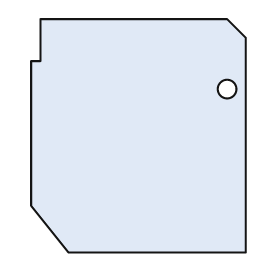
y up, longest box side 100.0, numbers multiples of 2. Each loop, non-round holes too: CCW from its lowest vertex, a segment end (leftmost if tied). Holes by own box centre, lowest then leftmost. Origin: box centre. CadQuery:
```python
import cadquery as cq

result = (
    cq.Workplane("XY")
    .moveTo(-30.0, -50.0)
    .lineTo(46.0, -50.0)
    .lineTo(46.0, 42.0)
    .lineTo(38.0, 50.0)
    .lineTo(-42.0, 50.0)
    .lineTo(-42.0, 32.0)
    .lineTo(-46.0, 32.0)
    .lineTo(-46.0, -30.0)
    .close()
    .moveTo(38.0, 20.0)
    .circle(4.0)
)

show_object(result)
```